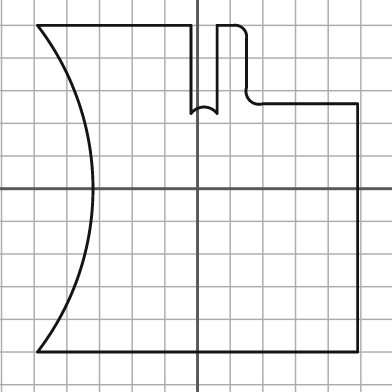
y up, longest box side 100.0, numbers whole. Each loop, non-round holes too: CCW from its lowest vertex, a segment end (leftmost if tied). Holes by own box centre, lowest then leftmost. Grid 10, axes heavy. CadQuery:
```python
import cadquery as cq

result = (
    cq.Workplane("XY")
    .moveTo(-49.0, -50.0)
    .lineTo(49.0, -50.0)
    .lineTo(49.0, 26.0)
    .lineTo(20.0, 26.0)
    .threePointArc((16.0, 27.0), (15.0, 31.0))
    .lineTo(15.0, 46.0)
    .threePointArc((14.0, 49.0), (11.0, 50.0))
    .lineTo(6.0, 50.0)
    .lineTo(6.0, 23.0)
    .threePointArc((2.0, 25.0), (-2.0, 23.0))
    .lineTo(-2.0, 50.0)
    .lineTo(-49.0, 50.0)
    .threePointArc((-32.0, 0.0), (-49.0, -50.0))
    .close()
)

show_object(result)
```